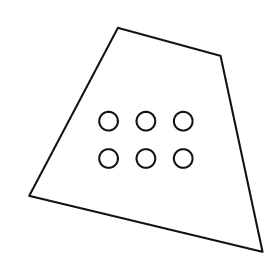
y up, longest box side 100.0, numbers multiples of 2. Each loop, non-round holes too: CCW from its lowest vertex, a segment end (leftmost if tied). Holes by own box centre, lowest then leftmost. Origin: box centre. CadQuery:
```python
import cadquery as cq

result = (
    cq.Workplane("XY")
    .moveTo(50.0, -48.0)
    .lineTo(32.0, 36.0)
    .lineTo(-12.0, 48.0)
    .lineTo(-50.0, -24.0)
    .close()
    .moveTo(-16.0, -8.0)
    .circle(4.0)
    .moveTo(0.0, -8.0)
    .circle(4.0)
    .moveTo(16.0, -8.0)
    .circle(4.0)
    .moveTo(-16.0, 8.0)
    .circle(4.0)
    .moveTo(0.0, 8.0)
    .circle(4.0)
    .moveTo(16.0, 8.0)
    .circle(4.0)
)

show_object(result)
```